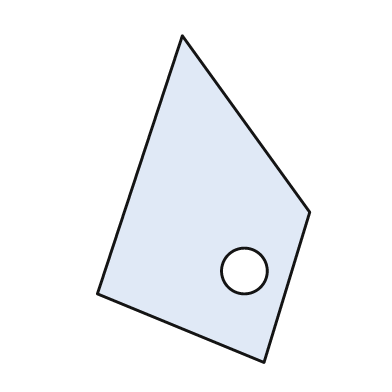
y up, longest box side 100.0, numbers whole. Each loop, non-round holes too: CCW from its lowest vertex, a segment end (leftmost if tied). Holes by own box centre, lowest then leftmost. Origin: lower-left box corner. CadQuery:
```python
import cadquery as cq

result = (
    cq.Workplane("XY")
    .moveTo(51.0, 0.0)
    .lineTo(65.0, 46.0)
    .lineTo(26.0, 100.0)
    .lineTo(0.0, 21.0)
    .close()
    .moveTo(45.0, 28.0)
    .circle(7.0)
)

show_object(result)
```